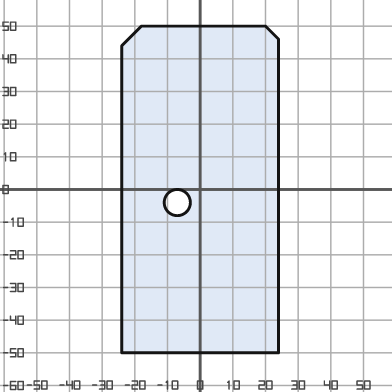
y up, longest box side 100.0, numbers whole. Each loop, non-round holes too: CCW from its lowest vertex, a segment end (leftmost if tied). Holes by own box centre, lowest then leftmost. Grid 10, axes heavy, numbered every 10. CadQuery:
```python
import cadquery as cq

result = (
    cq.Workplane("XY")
    .moveTo(-24.0, -50.0)
    .lineTo(24.0, -50.0)
    .lineTo(24.0, 46.0)
    .lineTo(20.0, 50.0)
    .lineTo(-18.0, 50.0)
    .lineTo(-24.0, 44.0)
    .close()
    .moveTo(-7.0, -4.0)
    .circle(4.0)
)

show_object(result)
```